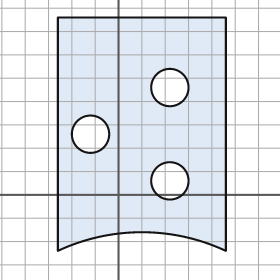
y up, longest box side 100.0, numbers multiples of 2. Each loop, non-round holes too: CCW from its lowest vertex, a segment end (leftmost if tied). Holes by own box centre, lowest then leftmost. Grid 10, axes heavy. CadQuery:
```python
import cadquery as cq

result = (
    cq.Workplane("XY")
    .moveTo(-26.0, -24.0)
    .threePointArc((10.0, -16.0), (46.0, -24.0))
    .lineTo(46.0, 76.0)
    .lineTo(-26.0, 76.0)
    .close()
    .moveTo(22.0, 6.0)
    .circle(8.0)
    .moveTo(-12.0, 26.0)
    .circle(8.0)
    .moveTo(22.0, 46.0)
    .circle(8.0)
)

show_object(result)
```